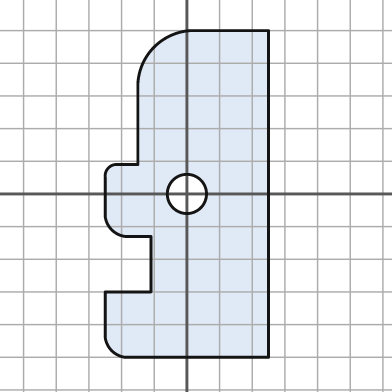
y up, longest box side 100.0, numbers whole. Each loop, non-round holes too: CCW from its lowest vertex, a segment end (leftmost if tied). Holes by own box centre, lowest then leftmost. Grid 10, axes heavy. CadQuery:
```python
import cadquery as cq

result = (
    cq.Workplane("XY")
    .moveTo(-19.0, -50.0)
    .lineTo(25.0, -50.0)
    .lineTo(25.0, 50.0)
    .lineTo(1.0, 50.0)
    .threePointArc((-10.0, 45.0), (-15.0, 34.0))
    .lineTo(-15.0, 9.0)
    .lineTo(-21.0, 9.0)
    .threePointArc((-24.0, 8.0), (-25.0, 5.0))
    .lineTo(-25.0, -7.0)
    .threePointArc((-23.0, -11.0), (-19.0, -13.0))
    .lineTo(-11.0, -13.0)
    .lineTo(-11.0, -30.0)
    .lineTo(-25.0, -30.0)
    .lineTo(-25.0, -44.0)
    .threePointArc((-23.0, -48.0), (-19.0, -50.0))
    .close()
    .moveTo(0.0, 0.0)
    .circle(6.0)
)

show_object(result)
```